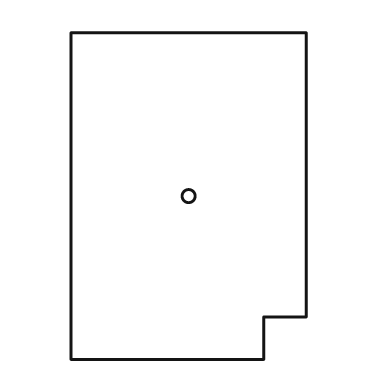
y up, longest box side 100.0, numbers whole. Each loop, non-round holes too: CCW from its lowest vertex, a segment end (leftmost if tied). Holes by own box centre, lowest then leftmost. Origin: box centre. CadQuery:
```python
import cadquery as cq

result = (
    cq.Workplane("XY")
    .moveTo(-36.0, -50.0)
    .lineTo(23.0, -50.0)
    .lineTo(23.0, -37.0)
    .lineTo(36.0, -37.0)
    .lineTo(36.0, 50.0)
    .lineTo(-36.0, 50.0)
    .close()
    .moveTo(0.0, 0.0)
    .circle(2.0)
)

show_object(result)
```